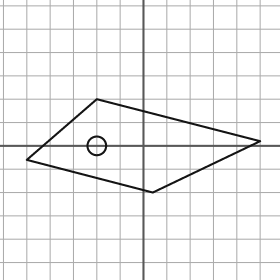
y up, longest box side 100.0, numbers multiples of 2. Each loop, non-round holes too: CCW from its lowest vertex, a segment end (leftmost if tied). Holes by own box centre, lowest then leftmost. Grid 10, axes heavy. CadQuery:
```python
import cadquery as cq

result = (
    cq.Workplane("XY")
    .moveTo(4.0, -20.0)
    .lineTo(50.0, 2.0)
    .lineTo(-20.0, 20.0)
    .lineTo(-50.0, -6.0)
    .close()
    .moveTo(-20.0, 0.0)
    .circle(4.0)
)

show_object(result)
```